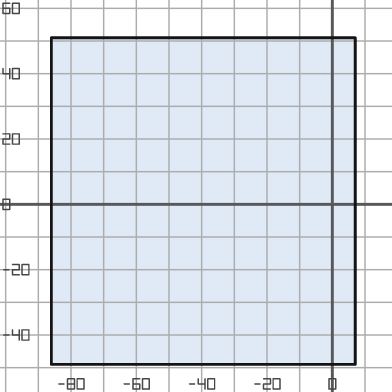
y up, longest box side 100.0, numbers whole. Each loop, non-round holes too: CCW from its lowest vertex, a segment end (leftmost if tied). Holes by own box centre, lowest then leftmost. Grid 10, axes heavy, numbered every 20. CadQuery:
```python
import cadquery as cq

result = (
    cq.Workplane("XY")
    .moveTo(-86.0, -49.0)
    .lineTo(7.0, -49.0)
    .lineTo(7.0, 51.0)
    .lineTo(-86.0, 51.0)
    .close()
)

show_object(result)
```